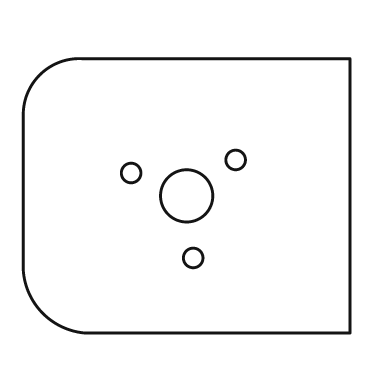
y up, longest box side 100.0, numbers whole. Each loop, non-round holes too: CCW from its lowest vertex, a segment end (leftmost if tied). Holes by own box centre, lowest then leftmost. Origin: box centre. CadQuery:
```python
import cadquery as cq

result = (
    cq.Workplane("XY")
    .moveTo(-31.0, -42.0)
    .lineTo(50.0, -42.0)
    .lineTo(50.0, 42.0)
    .lineTo(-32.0, 42.0)
    .threePointArc((-45.0, 37.0), (-50.0, 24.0))
    .lineTo(-50.0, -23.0)
    .threePointArc((-44.0, -36.0), (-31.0, -42.0))
    .close()
    .moveTo(2.0, -19.0)
    .circle(3.0)
    .moveTo(0.0, 0.0)
    .circle(8.0)
    .moveTo(-17.0, 7.0)
    .circle(3.0)
    .moveTo(15.0, 11.0)
    .circle(3.0)
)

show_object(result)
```